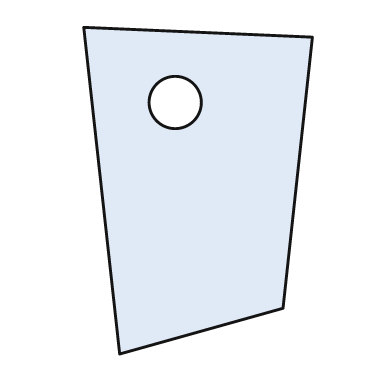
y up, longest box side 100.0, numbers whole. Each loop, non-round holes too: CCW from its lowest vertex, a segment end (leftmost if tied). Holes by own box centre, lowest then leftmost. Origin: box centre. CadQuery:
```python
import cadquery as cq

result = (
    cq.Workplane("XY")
    .moveTo(-24.0, -50.0)
    .lineTo(26.0, -36.0)
    .lineTo(35.0, 47.0)
    .lineTo(-35.0, 50.0)
    .close()
    .moveTo(-7.0, 27.0)
    .circle(8.0)
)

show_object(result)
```